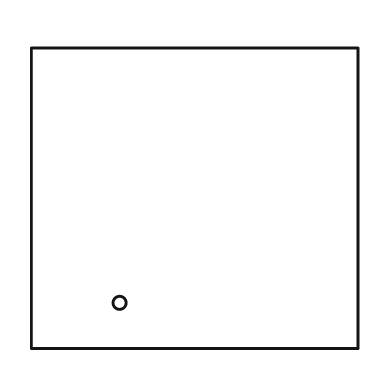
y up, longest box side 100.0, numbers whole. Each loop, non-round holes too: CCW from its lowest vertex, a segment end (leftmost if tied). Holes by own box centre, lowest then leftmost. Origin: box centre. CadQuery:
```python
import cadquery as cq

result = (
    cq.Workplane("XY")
    .moveTo(-50.0, -46.0)
    .lineTo(50.0, -46.0)
    .lineTo(50.0, 46.0)
    .lineTo(-50.0, 46.0)
    .close()
    .moveTo(-23.0, -32.0)
    .circle(2.0)
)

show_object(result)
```